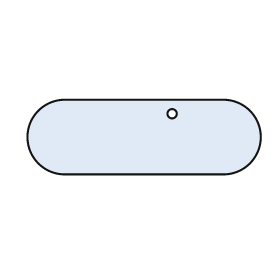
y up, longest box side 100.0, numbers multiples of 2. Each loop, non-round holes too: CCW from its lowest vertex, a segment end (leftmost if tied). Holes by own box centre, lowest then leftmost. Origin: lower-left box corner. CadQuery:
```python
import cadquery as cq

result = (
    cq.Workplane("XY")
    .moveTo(16.0, 0.0)
    .lineTo(84.0, 0.0)
    .threePointArc((100.0, 16.0), (84.0, 32.0))
    .lineTo(16.0, 32.0)
    .threePointArc((0.0, 16.0), (16.0, 0.0))
    .close()
    .moveTo(62.0, 26.0)
    .circle(2.0)
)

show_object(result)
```